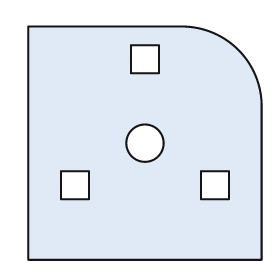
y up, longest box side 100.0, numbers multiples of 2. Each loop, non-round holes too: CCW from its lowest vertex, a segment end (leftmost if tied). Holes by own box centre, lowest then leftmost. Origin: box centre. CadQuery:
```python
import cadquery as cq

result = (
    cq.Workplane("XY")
    .moveTo(-50.0, -50.0)
    .lineTo(50.0, -50.0)
    .lineTo(50.0, 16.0)
    .threePointArc((40.0, 40.0), (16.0, 50.0))
    .lineTo(-50.0, 50.0)
    .close()
    .moveTo(-36.0, -24.0)
    .lineTo(-24.0, -24.0)
    .lineTo(-24.0, -12.0)
    .lineTo(-36.0, -12.0)
    .close()
    .moveTo(24.0, -24.0)
    .lineTo(36.0, -24.0)
    .lineTo(36.0, -12.0)
    .lineTo(24.0, -12.0)
    .close()
    .moveTo(0.0, 0.0)
    .circle(8.0)
    .moveTo(-6.0, 30.0)
    .lineTo(6.0, 30.0)
    .lineTo(6.0, 42.0)
    .lineTo(-6.0, 42.0)
    .close()
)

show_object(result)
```